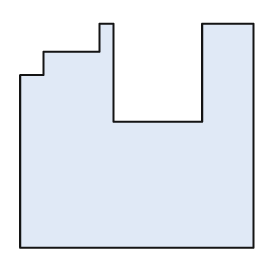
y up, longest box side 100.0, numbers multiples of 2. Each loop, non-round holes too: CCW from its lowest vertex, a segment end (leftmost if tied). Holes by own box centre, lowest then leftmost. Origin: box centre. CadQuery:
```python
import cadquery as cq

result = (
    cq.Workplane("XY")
    .moveTo(-50.0, -48.0)
    .lineTo(50.0, -48.0)
    .lineTo(50.0, 48.0)
    .lineTo(28.0, 48.0)
    .lineTo(28.0, 6.0)
    .lineTo(-10.0, 6.0)
    .lineTo(-10.0, 48.0)
    .lineTo(-16.0, 48.0)
    .lineTo(-16.0, 36.0)
    .lineTo(-40.0, 36.0)
    .lineTo(-40.0, 26.0)
    .lineTo(-50.0, 26.0)
    .close()
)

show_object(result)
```